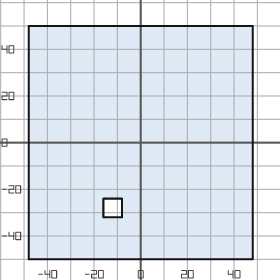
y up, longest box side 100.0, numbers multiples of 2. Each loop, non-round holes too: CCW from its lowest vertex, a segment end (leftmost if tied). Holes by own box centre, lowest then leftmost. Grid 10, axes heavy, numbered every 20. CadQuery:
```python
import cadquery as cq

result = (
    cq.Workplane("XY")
    .moveTo(-48.0, -50.0)
    .lineTo(48.0, -50.0)
    .lineTo(48.0, 50.0)
    .lineTo(-48.0, 50.0)
    .close()
    .moveTo(-16.0, -32.0)
    .lineTo(-8.0, -32.0)
    .lineTo(-8.0, -24.0)
    .lineTo(-16.0, -24.0)
    .close()
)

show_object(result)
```